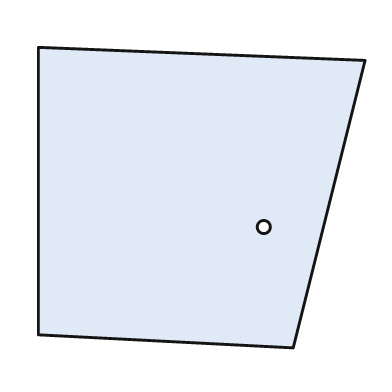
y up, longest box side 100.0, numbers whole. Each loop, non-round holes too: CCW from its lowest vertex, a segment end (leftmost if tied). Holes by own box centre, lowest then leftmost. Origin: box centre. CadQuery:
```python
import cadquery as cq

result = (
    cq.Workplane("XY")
    .moveTo(28.0, -46.0)
    .lineTo(50.0, 42.0)
    .lineTo(-50.0, 46.0)
    .lineTo(-50.0, -42.0)
    .close()
    .moveTo(19.0, -9.0)
    .circle(2.0)
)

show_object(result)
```